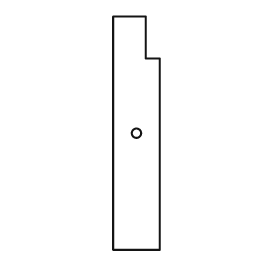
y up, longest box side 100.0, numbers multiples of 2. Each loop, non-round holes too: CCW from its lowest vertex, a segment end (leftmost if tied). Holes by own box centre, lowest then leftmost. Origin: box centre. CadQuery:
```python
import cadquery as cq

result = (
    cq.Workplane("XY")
    .moveTo(-10.0, -50.0)
    .lineTo(10.0, -50.0)
    .lineTo(10.0, 32.0)
    .lineTo(4.0, 32.0)
    .lineTo(4.0, 50.0)
    .lineTo(-10.0, 50.0)
    .close()
    .moveTo(0.0, 0.0)
    .circle(2.0)
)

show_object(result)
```